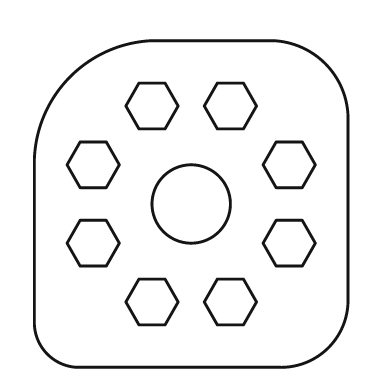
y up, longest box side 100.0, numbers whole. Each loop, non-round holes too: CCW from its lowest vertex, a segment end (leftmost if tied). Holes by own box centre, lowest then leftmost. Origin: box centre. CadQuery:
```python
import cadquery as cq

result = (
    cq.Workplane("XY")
    .moveTo(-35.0, -50.0)
    .lineTo(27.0, -50.0)
    .threePointArc((42.0, -44.0), (48.0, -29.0))
    .lineTo(48.0, 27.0)
    .threePointArc((41.0, 43.0), (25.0, 50.0))
    .lineTo(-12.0, 50.0)
    .threePointArc((-37.0, 39.0), (-48.0, 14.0))
    .lineTo(-48.0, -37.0)
    .threePointArc((-44.0, -46.0), (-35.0, -50.0))
    .close()
    .moveTo(-16.0, -37.0)
    .lineTo(-8.0, -37.0)
    .lineTo(-4.0, -30.0)
    .lineTo(-8.0, -23.0)
    .lineTo(-16.0, -23.0)
    .lineTo(-20.0, -30.0)
    .close()
    .moveTo(8.0, -37.0)
    .lineTo(16.0, -37.0)
    .lineTo(20.0, -30.0)
    .lineTo(16.0, -23.0)
    .lineTo(8.0, -23.0)
    .lineTo(4.0, -30.0)
    .close()
    .moveTo(-34.0, -19.0)
    .lineTo(-26.0, -19.0)
    .lineTo(-22.0, -12.0)
    .lineTo(-26.0, -5.0)
    .lineTo(-34.0, -5.0)
    .lineTo(-38.0, -12.0)
    .close()
    .moveTo(26.0, -19.0)
    .lineTo(34.0, -19.0)
    .lineTo(38.0, -12.0)
    .lineTo(34.0, -5.0)
    .lineTo(26.0, -5.0)
    .lineTo(22.0, -12.0)
    .close()
    .moveTo(0.0, 0.0)
    .circle(12.0)
    .moveTo(-34.0, 5.0)
    .lineTo(-26.0, 5.0)
    .lineTo(-22.0, 12.0)
    .lineTo(-26.0, 19.0)
    .lineTo(-34.0, 19.0)
    .lineTo(-38.0, 12.0)
    .close()
    .moveTo(26.0, 5.0)
    .lineTo(34.0, 5.0)
    .lineTo(38.0, 12.0)
    .lineTo(34.0, 19.0)
    .lineTo(26.0, 19.0)
    .lineTo(22.0, 12.0)
    .close()
    .moveTo(-16.0, 23.0)
    .lineTo(-8.0, 23.0)
    .lineTo(-4.0, 30.0)
    .lineTo(-8.0, 37.0)
    .lineTo(-16.0, 37.0)
    .lineTo(-20.0, 30.0)
    .close()
    .moveTo(8.0, 23.0)
    .lineTo(16.0, 23.0)
    .lineTo(20.0, 30.0)
    .lineTo(16.0, 37.0)
    .lineTo(8.0, 37.0)
    .lineTo(4.0, 30.0)
    .close()
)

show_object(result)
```